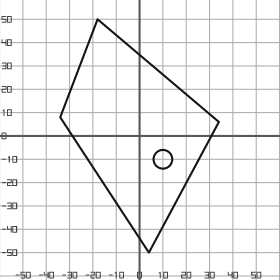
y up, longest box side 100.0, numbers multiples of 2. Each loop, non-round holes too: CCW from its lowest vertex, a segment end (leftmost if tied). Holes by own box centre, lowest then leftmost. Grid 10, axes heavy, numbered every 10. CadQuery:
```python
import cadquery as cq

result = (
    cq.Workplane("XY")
    .moveTo(4.0, -50.0)
    .lineTo(34.0, 6.0)
    .lineTo(-18.0, 50.0)
    .lineTo(-34.0, 8.0)
    .close()
    .moveTo(10.0, -10.0)
    .circle(4.0)
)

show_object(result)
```